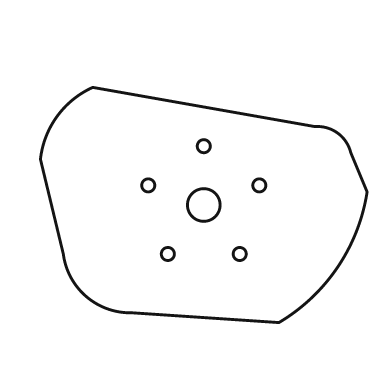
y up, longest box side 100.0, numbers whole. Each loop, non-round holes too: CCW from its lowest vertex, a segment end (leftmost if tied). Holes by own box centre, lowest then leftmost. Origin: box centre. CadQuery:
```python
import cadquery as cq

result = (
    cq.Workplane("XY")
    .moveTo(23.0, -36.0)
    .threePointArc((41.0, -19.0), (50.0, 4.0))
    .lineTo(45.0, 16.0)
    .threePointArc((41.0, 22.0), (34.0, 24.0))
    .lineTo(-34.0, 36.0)
    .threePointArc((-45.0, 27.0), (-50.0, 14.0))
    .lineTo(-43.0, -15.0)
    .threePointArc((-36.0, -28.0), (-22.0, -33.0))
    .close()
    .moveTo(-11.0, -15.0)
    .circle(2.0)
    .moveTo(11.0, -15.0)
    .circle(2.0)
    .moveTo(0.0, 0.0)
    .circle(5.0)
    .moveTo(-17.0, 6.0)
    .circle(2.0)
    .moveTo(17.0, 6.0)
    .circle(2.0)
    .moveTo(0.0, 18.0)
    .circle(2.0)
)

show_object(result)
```